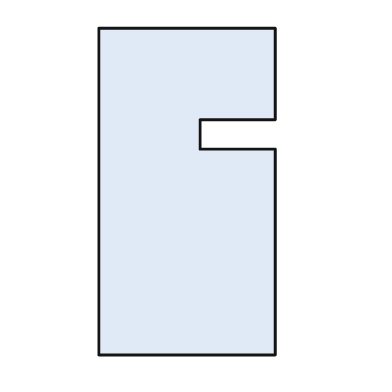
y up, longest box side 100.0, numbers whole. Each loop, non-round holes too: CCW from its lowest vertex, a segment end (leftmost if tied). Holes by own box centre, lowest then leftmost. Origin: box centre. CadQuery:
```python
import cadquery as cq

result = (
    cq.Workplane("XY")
    .moveTo(-27.0, -50.0)
    .lineTo(27.0, -50.0)
    .lineTo(27.0, 13.0)
    .lineTo(4.0, 13.0)
    .lineTo(4.0, 22.0)
    .lineTo(27.0, 22.0)
    .lineTo(27.0, 50.0)
    .lineTo(-27.0, 50.0)
    .close()
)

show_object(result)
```